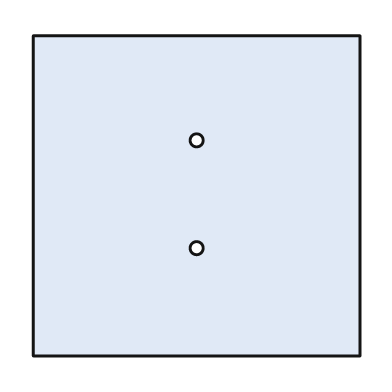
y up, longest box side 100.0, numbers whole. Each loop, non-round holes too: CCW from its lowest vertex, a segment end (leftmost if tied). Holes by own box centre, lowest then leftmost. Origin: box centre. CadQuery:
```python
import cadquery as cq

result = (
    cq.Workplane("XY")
    .moveTo(-50.0, -49.0)
    .lineTo(50.0, -49.0)
    .lineTo(50.0, 49.0)
    .lineTo(-50.0, 49.0)
    .close()
    .moveTo(0.0, -16.0)
    .circle(2.0)
    .moveTo(0.0, 17.0)
    .circle(2.0)
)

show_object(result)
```